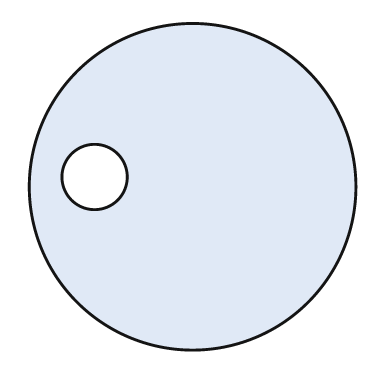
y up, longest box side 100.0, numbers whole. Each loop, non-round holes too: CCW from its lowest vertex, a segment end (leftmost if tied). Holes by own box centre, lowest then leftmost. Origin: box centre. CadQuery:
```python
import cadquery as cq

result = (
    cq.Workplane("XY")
    .moveTo(0.0, 0.0)
    .circle(50.0)
    .moveTo(-30.0, 3.0)
    .circle(10.0)
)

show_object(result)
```